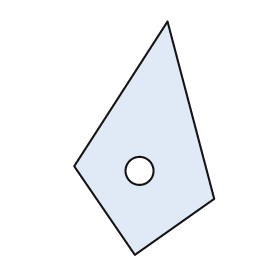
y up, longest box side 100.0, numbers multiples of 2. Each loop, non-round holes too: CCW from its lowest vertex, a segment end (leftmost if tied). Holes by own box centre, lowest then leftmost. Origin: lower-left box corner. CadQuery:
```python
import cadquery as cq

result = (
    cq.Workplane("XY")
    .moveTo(26.0, 0.0)
    .lineTo(60.0, 24.0)
    .lineTo(40.0, 100.0)
    .lineTo(0.0, 38.0)
    .close()
    .moveTo(28.0, 36.0)
    .circle(6.0)
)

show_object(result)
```